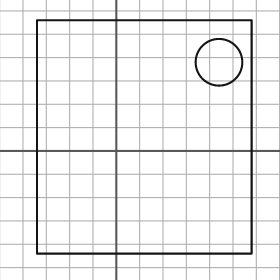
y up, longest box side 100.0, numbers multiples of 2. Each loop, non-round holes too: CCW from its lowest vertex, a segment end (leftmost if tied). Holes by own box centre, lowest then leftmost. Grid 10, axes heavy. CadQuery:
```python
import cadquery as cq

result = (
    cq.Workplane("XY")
    .moveTo(-34.0, -44.0)
    .lineTo(58.0, -44.0)
    .lineTo(58.0, 56.0)
    .lineTo(-34.0, 56.0)
    .close()
    .moveTo(44.0, 38.0)
    .circle(10.0)
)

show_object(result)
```